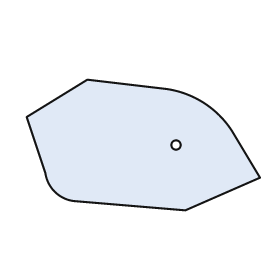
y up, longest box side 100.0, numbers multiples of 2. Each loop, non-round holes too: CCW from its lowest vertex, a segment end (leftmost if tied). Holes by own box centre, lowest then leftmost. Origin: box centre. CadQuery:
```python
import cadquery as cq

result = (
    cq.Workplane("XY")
    .moveTo(18.0, -28.0)
    .lineTo(50.0, -14.0)
    .lineTo(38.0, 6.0)
    .threePointArc((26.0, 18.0), (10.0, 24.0))
    .lineTo(-24.0, 28.0)
    .lineTo(-50.0, 12.0)
    .lineTo(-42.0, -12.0)
    .threePointArc((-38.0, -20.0), (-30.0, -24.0))
    .close()
    .moveTo(14.0, 0.0)
    .circle(2.0)
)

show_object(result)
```